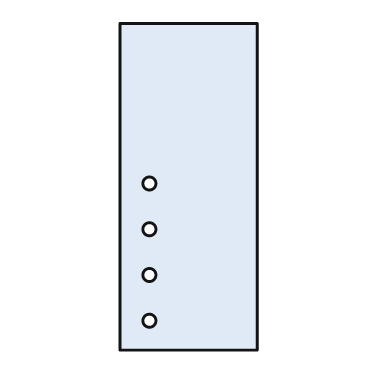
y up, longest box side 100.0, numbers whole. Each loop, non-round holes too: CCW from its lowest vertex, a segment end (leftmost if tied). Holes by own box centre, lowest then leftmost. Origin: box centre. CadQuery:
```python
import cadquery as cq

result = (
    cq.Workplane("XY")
    .moveTo(-21.0, -50.0)
    .lineTo(21.0, -50.0)
    .lineTo(21.0, 50.0)
    .lineTo(-21.0, 50.0)
    .close()
    .moveTo(-12.0, -41.0)
    .circle(2.0)
    .moveTo(-12.0, -27.0)
    .circle(2.0)
    .moveTo(-12.0, -13.0)
    .circle(2.0)
    .moveTo(-12.0, 1.0)
    .circle(2.0)
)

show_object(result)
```